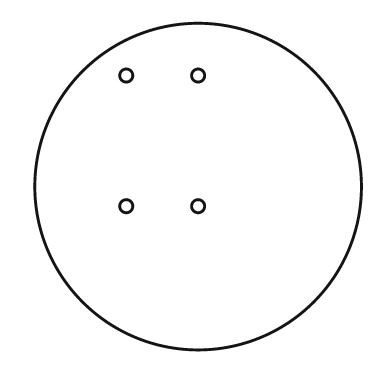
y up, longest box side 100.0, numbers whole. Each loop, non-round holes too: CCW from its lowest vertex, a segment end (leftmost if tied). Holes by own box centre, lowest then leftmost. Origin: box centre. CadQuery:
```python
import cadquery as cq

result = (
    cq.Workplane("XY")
    .moveTo(0.0, 0.0)
    .circle(50.0)
    .moveTo(-22.0, -6.0)
    .circle(2.0)
    .moveTo(0.0, -6.0)
    .circle(2.0)
    .moveTo(-22.0, 34.0)
    .circle(2.0)
    .moveTo(0.0, 34.0)
    .circle(2.0)
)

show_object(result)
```